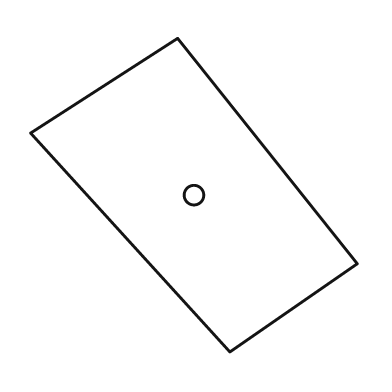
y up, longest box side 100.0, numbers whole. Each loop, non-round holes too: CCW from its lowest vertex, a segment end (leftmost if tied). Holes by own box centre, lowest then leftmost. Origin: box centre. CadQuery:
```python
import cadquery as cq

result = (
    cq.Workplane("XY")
    .moveTo(11.0, -48.0)
    .lineTo(50.0, -21.0)
    .lineTo(-5.0, 48.0)
    .lineTo(-50.0, 19.0)
    .close()
    .moveTo(0.0, 0.0)
    .circle(3.0)
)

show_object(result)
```